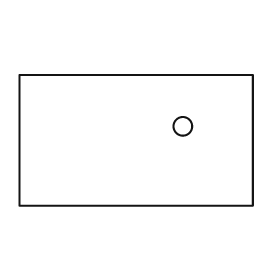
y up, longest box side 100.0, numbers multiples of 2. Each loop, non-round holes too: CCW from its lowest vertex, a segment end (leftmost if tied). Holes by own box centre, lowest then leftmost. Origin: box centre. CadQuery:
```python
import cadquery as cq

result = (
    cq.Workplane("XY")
    .moveTo(-50.0, -28.0)
    .lineTo(50.0, -28.0)
    .lineTo(50.0, 28.0)
    .lineTo(-50.0, 28.0)
    .close()
    .moveTo(20.0, 6.0)
    .circle(4.0)
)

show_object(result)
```